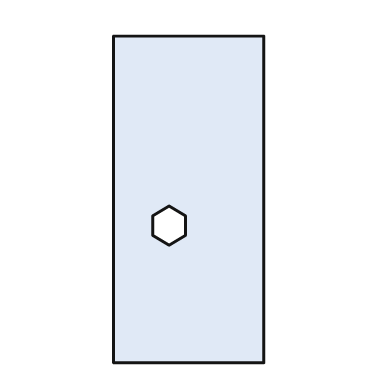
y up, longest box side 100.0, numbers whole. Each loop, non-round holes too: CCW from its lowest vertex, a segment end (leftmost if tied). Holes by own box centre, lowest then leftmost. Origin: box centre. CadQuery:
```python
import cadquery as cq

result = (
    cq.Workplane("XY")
    .moveTo(-23.0, -50.0)
    .lineTo(23.0, -50.0)
    .lineTo(23.0, 50.0)
    .lineTo(-23.0, 50.0)
    .close()
    .moveTo(-6.0, -14.0)
    .lineTo(-1.0, -11.0)
    .lineTo(-1.0, -5.0)
    .lineTo(-6.0, -2.0)
    .lineTo(-11.0, -5.0)
    .lineTo(-11.0, -11.0)
    .close()
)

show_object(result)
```